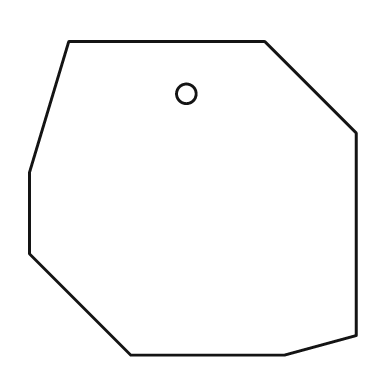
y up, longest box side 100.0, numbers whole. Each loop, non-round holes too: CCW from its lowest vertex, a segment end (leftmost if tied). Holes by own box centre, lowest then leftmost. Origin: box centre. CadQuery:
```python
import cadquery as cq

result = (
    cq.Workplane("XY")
    .moveTo(-19.0, -48.0)
    .lineTo(28.0, -48.0)
    .lineTo(50.0, -42.0)
    .lineTo(50.0, 20.0)
    .lineTo(22.0, 48.0)
    .lineTo(-38.0, 48.0)
    .lineTo(-50.0, 8.0)
    .lineTo(-50.0, -17.0)
    .close()
    .moveTo(-2.0, 32.0)
    .circle(3.0)
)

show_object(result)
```